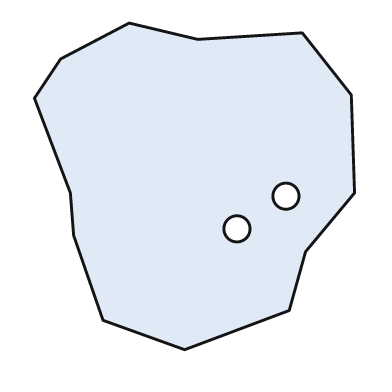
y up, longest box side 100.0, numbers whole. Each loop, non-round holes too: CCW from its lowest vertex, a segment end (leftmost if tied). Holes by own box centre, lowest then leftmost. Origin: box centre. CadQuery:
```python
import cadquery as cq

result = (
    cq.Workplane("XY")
    .moveTo(-3.0, -50.0)
    .lineTo(29.0, -38.0)
    .lineTo(34.0, -20.0)
    .lineTo(49.0, -2.0)
    .lineTo(48.0, 28.0)
    .lineTo(33.0, 47.0)
    .lineTo(1.0, 45.0)
    .lineTo(-20.0, 50.0)
    .lineTo(-41.0, 39.0)
    .lineTo(-49.0, 27.0)
    .lineTo(-38.0, -2.0)
    .lineTo(-37.0, -15.0)
    .lineTo(-28.0, -41.0)
    .close()
    .moveTo(13.0, -13.0)
    .circle(4.0)
    .moveTo(28.0, -3.0)
    .circle(4.0)
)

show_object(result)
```